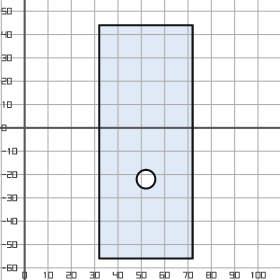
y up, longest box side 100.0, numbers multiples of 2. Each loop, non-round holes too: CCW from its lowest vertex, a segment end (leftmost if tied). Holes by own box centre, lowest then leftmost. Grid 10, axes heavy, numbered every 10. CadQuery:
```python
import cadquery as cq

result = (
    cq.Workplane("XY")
    .moveTo(32.0, -56.0)
    .lineTo(72.0, -56.0)
    .lineTo(72.0, 44.0)
    .lineTo(32.0, 44.0)
    .close()
    .moveTo(52.0, -22.0)
    .circle(4.0)
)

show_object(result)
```